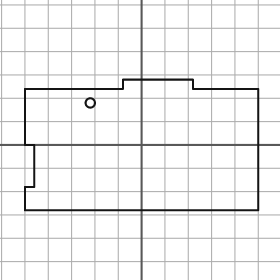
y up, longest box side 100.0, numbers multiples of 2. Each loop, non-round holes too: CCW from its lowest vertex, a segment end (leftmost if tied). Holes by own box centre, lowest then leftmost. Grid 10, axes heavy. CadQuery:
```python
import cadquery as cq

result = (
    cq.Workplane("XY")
    .moveTo(-50.0, -28.0)
    .lineTo(50.0, -28.0)
    .lineTo(50.0, 24.0)
    .lineTo(22.0, 24.0)
    .lineTo(22.0, 28.0)
    .lineTo(-8.0, 28.0)
    .lineTo(-8.0, 24.0)
    .lineTo(-50.0, 24.0)
    .lineTo(-50.0, 0.0)
    .lineTo(-46.0, 0.0)
    .lineTo(-46.0, -18.0)
    .lineTo(-50.0, -18.0)
    .close()
    .moveTo(-22.0, 18.0)
    .circle(2.0)
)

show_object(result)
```